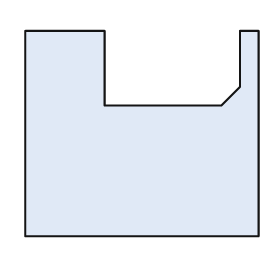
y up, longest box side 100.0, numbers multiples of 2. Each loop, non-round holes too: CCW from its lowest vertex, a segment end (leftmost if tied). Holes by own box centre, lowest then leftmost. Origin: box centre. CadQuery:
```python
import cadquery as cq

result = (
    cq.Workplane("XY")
    .moveTo(-50.0, -44.0)
    .lineTo(50.0, -44.0)
    .lineTo(50.0, 44.0)
    .lineTo(42.0, 44.0)
    .lineTo(42.0, 20.0)
    .lineTo(34.0, 12.0)
    .lineTo(-16.0, 12.0)
    .lineTo(-16.0, 44.0)
    .lineTo(-50.0, 44.0)
    .close()
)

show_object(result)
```